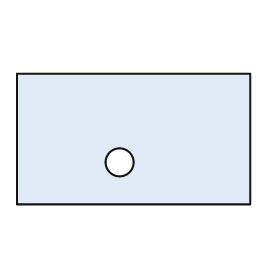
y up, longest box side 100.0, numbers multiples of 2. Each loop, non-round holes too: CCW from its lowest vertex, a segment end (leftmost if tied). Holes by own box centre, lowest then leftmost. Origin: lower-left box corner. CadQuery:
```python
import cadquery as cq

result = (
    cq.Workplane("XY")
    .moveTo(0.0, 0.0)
    .lineTo(100.0, 0.0)
    .lineTo(100.0, 56.0)
    .lineTo(0.0, 56.0)
    .close()
    .moveTo(44.0, 18.0)
    .circle(6.0)
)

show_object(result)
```